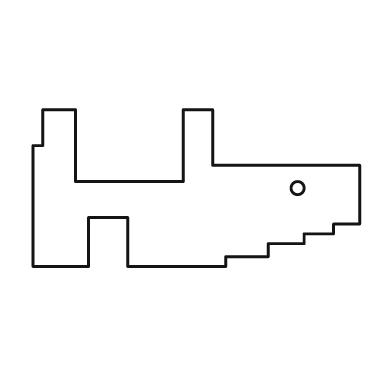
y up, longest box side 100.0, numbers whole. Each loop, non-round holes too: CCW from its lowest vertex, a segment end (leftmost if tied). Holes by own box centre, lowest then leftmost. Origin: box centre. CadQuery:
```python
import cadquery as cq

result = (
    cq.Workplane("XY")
    .moveTo(-50.0, -24.0)
    .lineTo(-33.0, -24.0)
    .lineTo(-33.0, -9.0)
    .lineTo(-21.0, -9.0)
    .lineTo(-21.0, -24.0)
    .lineTo(9.0, -24.0)
    .lineTo(9.0, -21.0)
    .lineTo(22.0, -21.0)
    .lineTo(22.0, -17.0)
    .lineTo(33.0, -17.0)
    .lineTo(33.0, -14.0)
    .lineTo(42.0, -14.0)
    .lineTo(42.0, -11.0)
    .lineTo(50.0, -11.0)
    .lineTo(50.0, 7.0)
    .lineTo(5.0, 7.0)
    .lineTo(5.0, 24.0)
    .lineTo(-4.0, 24.0)
    .lineTo(-4.0, 2.0)
    .lineTo(-37.0, 2.0)
    .lineTo(-37.0, 24.0)
    .lineTo(-47.0, 24.0)
    .lineTo(-47.0, 13.0)
    .lineTo(-50.0, 13.0)
    .close()
    .moveTo(31.0, 0.0)
    .circle(2.0)
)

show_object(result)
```